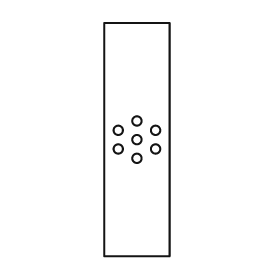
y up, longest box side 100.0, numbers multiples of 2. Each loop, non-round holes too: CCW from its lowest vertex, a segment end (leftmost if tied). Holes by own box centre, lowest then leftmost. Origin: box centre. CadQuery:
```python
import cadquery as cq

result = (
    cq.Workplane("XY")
    .moveTo(-14.0, -50.0)
    .lineTo(14.0, -50.0)
    .lineTo(14.0, 50.0)
    .lineTo(-14.0, 50.0)
    .close()
    .moveTo(0.0, -8.0)
    .circle(2.0)
    .moveTo(-8.0, -4.0)
    .circle(2.0)
    .moveTo(8.0, -4.0)
    .circle(2.0)
    .moveTo(0.0, 0.0)
    .circle(2.0)
    .moveTo(-8.0, 4.0)
    .circle(2.0)
    .moveTo(8.0, 4.0)
    .circle(2.0)
    .moveTo(0.0, 8.0)
    .circle(2.0)
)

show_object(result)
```